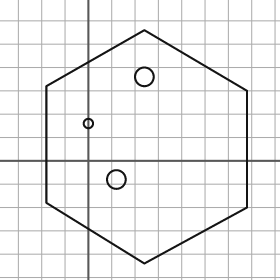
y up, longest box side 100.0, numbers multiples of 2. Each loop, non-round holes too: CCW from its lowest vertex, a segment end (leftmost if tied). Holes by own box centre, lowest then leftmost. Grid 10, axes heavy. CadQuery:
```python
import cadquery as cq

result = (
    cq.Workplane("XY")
    .moveTo(24.0, -44.0)
    .lineTo(68.0, -20.0)
    .lineTo(68.0, 30.0)
    .lineTo(24.0, 56.0)
    .lineTo(-18.0, 32.0)
    .lineTo(-18.0, -18.0)
    .close()
    .moveTo(12.0, -8.0)
    .circle(4.0)
    .moveTo(0.0, 16.0)
    .circle(2.0)
    .moveTo(24.0, 36.0)
    .circle(4.0)
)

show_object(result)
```